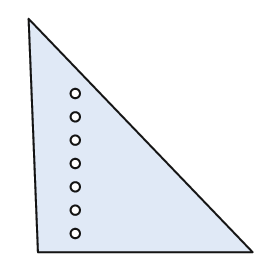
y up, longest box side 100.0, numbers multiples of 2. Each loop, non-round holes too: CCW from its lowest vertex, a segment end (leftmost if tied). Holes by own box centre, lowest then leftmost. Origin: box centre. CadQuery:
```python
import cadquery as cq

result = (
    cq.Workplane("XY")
    .moveTo(-44.0, -50.0)
    .lineTo(48.0, -50.0)
    .lineTo(-48.0, 50.0)
    .close()
    .moveTo(-28.0, -42.0)
    .circle(2.0)
    .moveTo(-28.0, -32.0)
    .circle(2.0)
    .moveTo(-28.0, -22.0)
    .circle(2.0)
    .moveTo(-28.0, -12.0)
    .circle(2.0)
    .moveTo(-28.0, -2.0)
    .circle(2.0)
    .moveTo(-28.0, 8.0)
    .circle(2.0)
    .moveTo(-28.0, 18.0)
    .circle(2.0)
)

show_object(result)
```